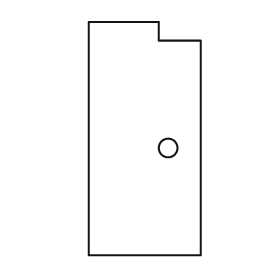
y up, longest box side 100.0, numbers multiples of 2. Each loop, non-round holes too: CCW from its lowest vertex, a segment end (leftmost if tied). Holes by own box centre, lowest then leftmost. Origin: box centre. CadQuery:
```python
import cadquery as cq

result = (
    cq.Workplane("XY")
    .moveTo(-24.0, -50.0)
    .lineTo(24.0, -50.0)
    .lineTo(24.0, 42.0)
    .lineTo(6.0, 42.0)
    .lineTo(6.0, 50.0)
    .lineTo(-24.0, 50.0)
    .close()
    .moveTo(10.0, -4.0)
    .circle(4.0)
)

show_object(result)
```